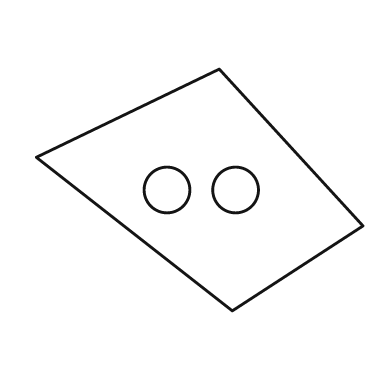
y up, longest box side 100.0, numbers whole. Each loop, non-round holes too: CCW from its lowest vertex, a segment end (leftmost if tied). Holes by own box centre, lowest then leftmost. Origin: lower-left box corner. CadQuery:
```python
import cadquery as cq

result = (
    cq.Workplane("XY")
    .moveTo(60.0, 0.0)
    .lineTo(100.0, 26.0)
    .lineTo(56.0, 74.0)
    .lineTo(0.0, 47.0)
    .close()
    .moveTo(40.0, 37.0)
    .circle(7.0)
    .moveTo(61.0, 37.0)
    .circle(7.0)
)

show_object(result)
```